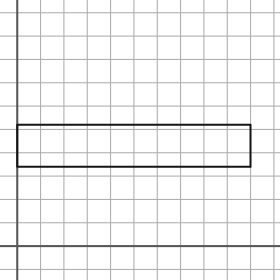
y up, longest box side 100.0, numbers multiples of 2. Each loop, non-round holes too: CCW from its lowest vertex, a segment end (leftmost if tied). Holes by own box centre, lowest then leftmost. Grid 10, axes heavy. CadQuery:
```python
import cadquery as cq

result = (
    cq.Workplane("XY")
    .moveTo(0.0, 34.0)
    .lineTo(100.0, 34.0)
    .lineTo(100.0, 52.0)
    .lineTo(0.0, 52.0)
    .close()
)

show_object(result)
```